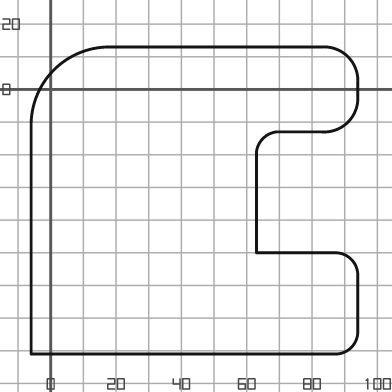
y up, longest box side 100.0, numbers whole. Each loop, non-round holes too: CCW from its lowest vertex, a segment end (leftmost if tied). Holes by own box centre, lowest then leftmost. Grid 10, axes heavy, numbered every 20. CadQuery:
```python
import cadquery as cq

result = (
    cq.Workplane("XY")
    .moveTo(-6.0, -81.0)
    .lineTo(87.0, -81.0)
    .threePointArc((92.0, -79.0), (94.0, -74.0))
    .lineTo(94.0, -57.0)
    .threePointArc((92.0, -52.0), (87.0, -50.0))
    .lineTo(63.0, -50.0)
    .lineTo(63.0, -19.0)
    .threePointArc((65.0, -15.0), (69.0, -13.0))
    .lineTo(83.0, -13.0)
    .threePointArc((91.0, -10.0), (94.0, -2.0))
    .lineTo(94.0, 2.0)
    .threePointArc((91.0, 10.0), (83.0, 13.0))
    .lineTo(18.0, 13.0)
    .threePointArc((1.0, 6.0), (-6.0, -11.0))
    .close()
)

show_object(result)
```